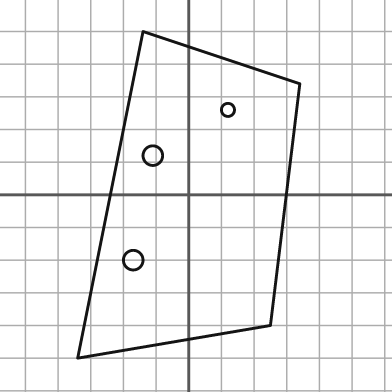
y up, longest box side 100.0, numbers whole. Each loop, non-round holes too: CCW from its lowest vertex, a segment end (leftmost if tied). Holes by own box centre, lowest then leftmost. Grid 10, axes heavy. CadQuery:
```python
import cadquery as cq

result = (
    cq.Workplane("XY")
    .moveTo(-34.0, -50.0)
    .lineTo(25.0, -40.0)
    .lineTo(34.0, 34.0)
    .lineTo(-14.0, 50.0)
    .close()
    .moveTo(-17.0, -20.0)
    .circle(3.0)
    .moveTo(-11.0, 12.0)
    .circle(3.0)
    .moveTo(12.0, 26.0)
    .circle(2.0)
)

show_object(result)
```